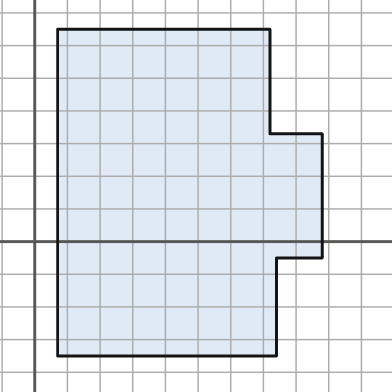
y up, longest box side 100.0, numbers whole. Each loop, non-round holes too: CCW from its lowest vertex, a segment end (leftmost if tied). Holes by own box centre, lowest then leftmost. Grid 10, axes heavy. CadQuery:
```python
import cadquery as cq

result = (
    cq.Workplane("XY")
    .moveTo(7.0, -35.0)
    .lineTo(74.0, -35.0)
    .lineTo(74.0, -5.0)
    .lineTo(88.0, -5.0)
    .lineTo(88.0, 33.0)
    .lineTo(72.0, 33.0)
    .lineTo(72.0, 65.0)
    .lineTo(7.0, 65.0)
    .close()
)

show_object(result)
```